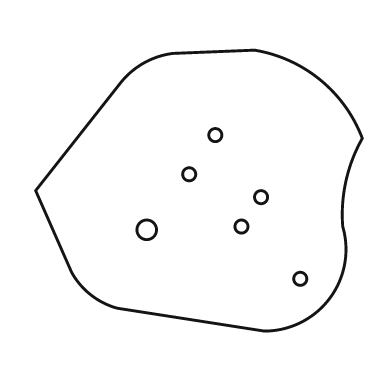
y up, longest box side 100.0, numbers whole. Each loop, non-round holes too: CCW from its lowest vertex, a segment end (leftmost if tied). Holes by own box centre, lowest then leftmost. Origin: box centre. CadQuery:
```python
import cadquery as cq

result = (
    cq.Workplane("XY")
    .moveTo(20.0, -43.0)
    .threePointArc((40.0, -33.0), (44.0, -11.0))
    .threePointArc((45.0, 3.0), (50.0, 16.0))
    .threePointArc((37.0, 34.0), (17.0, 43.0))
    .lineTo(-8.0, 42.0)
    .threePointArc((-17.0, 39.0), (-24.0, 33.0))
    .lineTo(-50.0, 0.0)
    .lineTo(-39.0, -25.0)
    .threePointArc((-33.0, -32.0), (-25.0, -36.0))
    .close()
    .moveTo(31.0, -27.0)
    .circle(2.0)
    .moveTo(-16.0, -12.0)
    .circle(3.0)
    .moveTo(13.0, -11.0)
    .circle(2.0)
    .moveTo(19.0, -2.0)
    .circle(2.0)
    .moveTo(-3.0, 5.0)
    .circle(2.0)
    .moveTo(5.0, 17.0)
    .circle(2.0)
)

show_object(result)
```